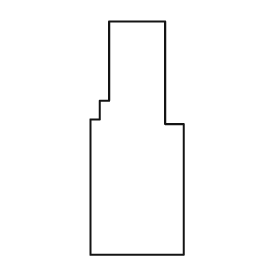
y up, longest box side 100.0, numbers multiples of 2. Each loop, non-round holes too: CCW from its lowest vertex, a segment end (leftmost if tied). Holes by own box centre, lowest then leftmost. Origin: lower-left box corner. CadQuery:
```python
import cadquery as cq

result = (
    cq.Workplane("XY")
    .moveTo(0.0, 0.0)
    .lineTo(40.0, 0.0)
    .lineTo(40.0, 56.0)
    .lineTo(32.0, 56.0)
    .lineTo(32.0, 100.0)
    .lineTo(8.0, 100.0)
    .lineTo(8.0, 66.0)
    .lineTo(4.0, 66.0)
    .lineTo(4.0, 58.0)
    .lineTo(0.0, 58.0)
    .close()
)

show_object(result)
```